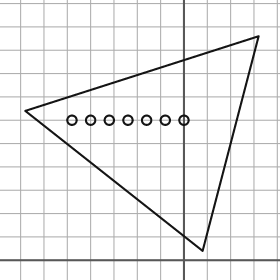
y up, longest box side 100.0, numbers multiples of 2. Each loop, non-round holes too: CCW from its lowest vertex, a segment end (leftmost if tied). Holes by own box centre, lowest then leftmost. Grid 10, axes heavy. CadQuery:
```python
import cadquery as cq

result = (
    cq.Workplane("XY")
    .moveTo(8.0, 4.0)
    .lineTo(32.0, 96.0)
    .lineTo(-68.0, 64.0)
    .close()
    .moveTo(-48.0, 60.0)
    .circle(2.0)
    .moveTo(-40.0, 60.0)
    .circle(2.0)
    .moveTo(-32.0, 60.0)
    .circle(2.0)
    .moveTo(-24.0, 60.0)
    .circle(2.0)
    .moveTo(-16.0, 60.0)
    .circle(2.0)
    .moveTo(-8.0, 60.0)
    .circle(2.0)
    .moveTo(0.0, 60.0)
    .circle(2.0)
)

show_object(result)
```